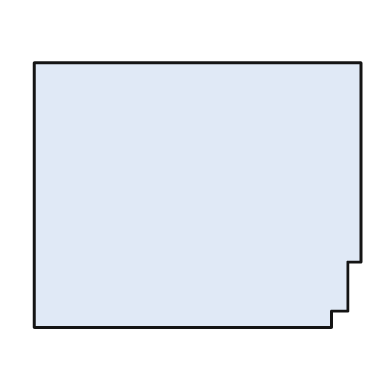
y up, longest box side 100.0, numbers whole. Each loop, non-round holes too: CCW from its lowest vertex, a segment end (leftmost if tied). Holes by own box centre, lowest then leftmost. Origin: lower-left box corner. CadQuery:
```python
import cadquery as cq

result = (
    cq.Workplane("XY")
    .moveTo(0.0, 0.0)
    .lineTo(91.0, 0.0)
    .lineTo(91.0, 5.0)
    .lineTo(96.0, 5.0)
    .lineTo(96.0, 20.0)
    .lineTo(100.0, 20.0)
    .lineTo(100.0, 81.0)
    .lineTo(0.0, 81.0)
    .close()
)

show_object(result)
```